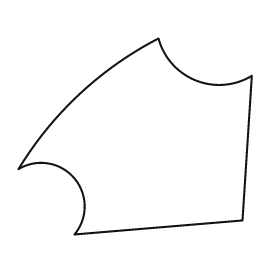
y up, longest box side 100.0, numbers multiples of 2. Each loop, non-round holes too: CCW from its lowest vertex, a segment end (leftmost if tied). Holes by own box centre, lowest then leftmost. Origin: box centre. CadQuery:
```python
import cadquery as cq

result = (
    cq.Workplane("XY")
    .moveTo(-26.0, -42.0)
    .lineTo(46.0, -36.0)
    .lineTo(50.0, 26.0)
    .threePointArc((26.0, 24.0), (10.0, 42.0))
    .threePointArc((-24.0, 18.0), (-50.0, -14.0))
    .threePointArc((-26.0, -18.0), (-26.0, -42.0))
    .close()
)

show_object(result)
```